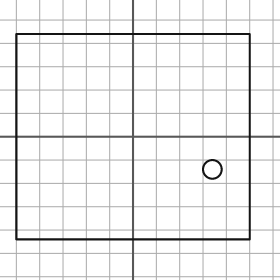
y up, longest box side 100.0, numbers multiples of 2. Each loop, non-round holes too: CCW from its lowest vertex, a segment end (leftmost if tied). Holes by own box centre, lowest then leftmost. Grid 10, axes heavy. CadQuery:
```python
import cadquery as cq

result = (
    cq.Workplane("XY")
    .moveTo(-50.0, -44.0)
    .lineTo(50.0, -44.0)
    .lineTo(50.0, 44.0)
    .lineTo(-50.0, 44.0)
    .close()
    .moveTo(34.0, -14.0)
    .circle(4.0)
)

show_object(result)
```